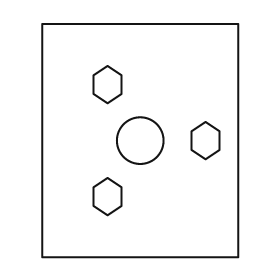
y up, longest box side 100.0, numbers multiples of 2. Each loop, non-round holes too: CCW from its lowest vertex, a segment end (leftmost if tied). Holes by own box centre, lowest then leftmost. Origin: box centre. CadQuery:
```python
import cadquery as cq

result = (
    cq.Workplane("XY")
    .moveTo(-42.0, -50.0)
    .lineTo(42.0, -50.0)
    .lineTo(42.0, 50.0)
    .lineTo(-42.0, 50.0)
    .close()
    .moveTo(-14.0, -32.0)
    .lineTo(-8.0, -28.0)
    .lineTo(-8.0, -20.0)
    .lineTo(-14.0, -16.0)
    .lineTo(-20.0, -20.0)
    .lineTo(-20.0, -28.0)
    .close()
    .moveTo(0.0, 0.0)
    .circle(10.0)
    .moveTo(28.0, -8.0)
    .lineTo(34.0, -4.0)
    .lineTo(34.0, 4.0)
    .lineTo(28.0, 8.0)
    .lineTo(22.0, 4.0)
    .lineTo(22.0, -4.0)
    .close()
    .moveTo(-14.0, 16.0)
    .lineTo(-8.0, 20.0)
    .lineTo(-8.0, 28.0)
    .lineTo(-14.0, 32.0)
    .lineTo(-20.0, 28.0)
    .lineTo(-20.0, 20.0)
    .close()
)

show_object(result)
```